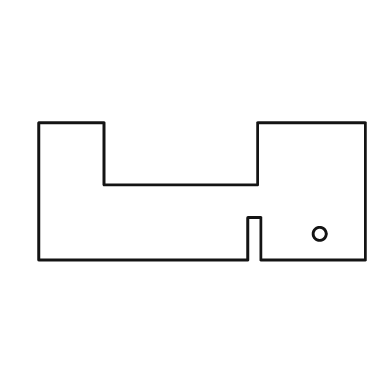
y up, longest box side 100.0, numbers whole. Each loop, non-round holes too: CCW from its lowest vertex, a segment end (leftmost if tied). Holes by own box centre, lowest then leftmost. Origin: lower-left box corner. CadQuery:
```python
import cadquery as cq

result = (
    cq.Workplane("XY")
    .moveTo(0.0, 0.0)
    .lineTo(64.0, 0.0)
    .lineTo(64.0, 13.0)
    .lineTo(68.0, 13.0)
    .lineTo(68.0, 0.0)
    .lineTo(100.0, 0.0)
    .lineTo(100.0, 42.0)
    .lineTo(67.0, 42.0)
    .lineTo(67.0, 23.0)
    .lineTo(20.0, 23.0)
    .lineTo(20.0, 42.0)
    .lineTo(0.0, 42.0)
    .close()
    .moveTo(86.0, 8.0)
    .circle(2.0)
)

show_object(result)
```